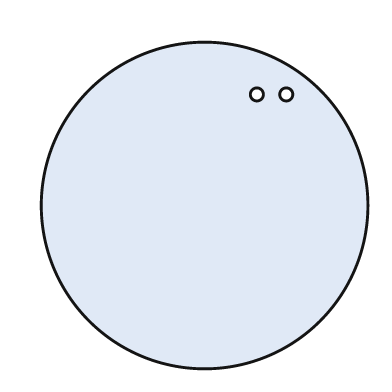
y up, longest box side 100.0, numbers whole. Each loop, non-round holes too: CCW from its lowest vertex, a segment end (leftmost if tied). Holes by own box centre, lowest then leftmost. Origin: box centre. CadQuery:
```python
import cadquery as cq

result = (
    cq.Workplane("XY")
    .moveTo(0.0, 0.0)
    .circle(50.0)
    .moveTo(16.0, 34.0)
    .circle(2.0)
    .moveTo(25.0, 34.0)
    .circle(2.0)
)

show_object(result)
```